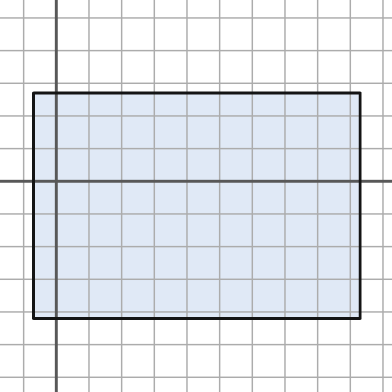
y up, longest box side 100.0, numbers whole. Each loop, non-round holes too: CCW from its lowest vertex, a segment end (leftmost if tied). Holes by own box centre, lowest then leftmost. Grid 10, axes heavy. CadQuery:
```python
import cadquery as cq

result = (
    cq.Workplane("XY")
    .moveTo(-7.0, -42.0)
    .lineTo(93.0, -42.0)
    .lineTo(93.0, 27.0)
    .lineTo(-7.0, 27.0)
    .close()
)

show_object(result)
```